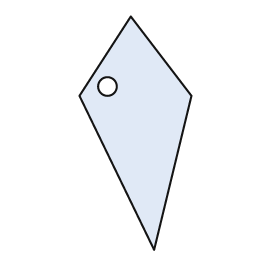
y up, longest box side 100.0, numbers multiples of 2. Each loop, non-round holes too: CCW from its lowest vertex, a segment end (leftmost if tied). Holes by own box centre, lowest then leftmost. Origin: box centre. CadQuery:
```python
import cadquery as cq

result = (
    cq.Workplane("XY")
    .moveTo(8.0, -50.0)
    .lineTo(24.0, 16.0)
    .lineTo(-2.0, 50.0)
    .lineTo(-24.0, 16.0)
    .close()
    .moveTo(-12.0, 20.0)
    .circle(4.0)
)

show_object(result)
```